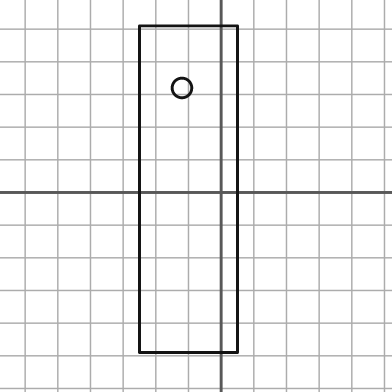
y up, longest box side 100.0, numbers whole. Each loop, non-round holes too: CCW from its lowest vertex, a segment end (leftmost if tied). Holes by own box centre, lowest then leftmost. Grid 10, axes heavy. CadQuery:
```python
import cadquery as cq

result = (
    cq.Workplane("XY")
    .moveTo(-25.0, -49.0)
    .lineTo(5.0, -49.0)
    .lineTo(5.0, 51.0)
    .lineTo(-25.0, 51.0)
    .close()
    .moveTo(-12.0, 32.0)
    .circle(3.0)
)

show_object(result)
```